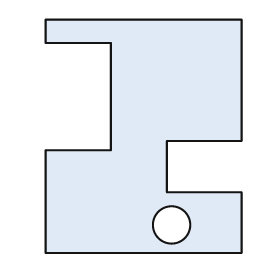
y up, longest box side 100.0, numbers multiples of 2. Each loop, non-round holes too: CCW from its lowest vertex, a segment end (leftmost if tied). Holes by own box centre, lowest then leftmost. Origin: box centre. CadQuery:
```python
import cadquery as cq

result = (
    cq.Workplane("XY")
    .moveTo(-42.0, -50.0)
    .lineTo(42.0, -50.0)
    .lineTo(42.0, -24.0)
    .lineTo(10.0, -24.0)
    .lineTo(10.0, -2.0)
    .lineTo(42.0, -2.0)
    .lineTo(42.0, 50.0)
    .lineTo(-42.0, 50.0)
    .lineTo(-42.0, 40.0)
    .lineTo(-14.0, 40.0)
    .lineTo(-14.0, -6.0)
    .lineTo(-42.0, -6.0)
    .close()
    .moveTo(12.0, -38.0)
    .circle(8.0)
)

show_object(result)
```